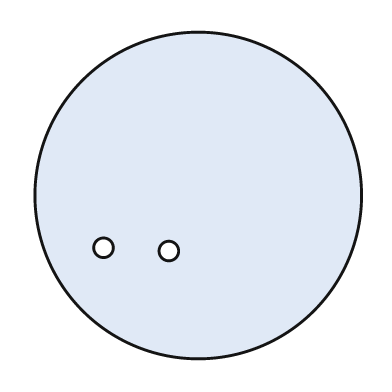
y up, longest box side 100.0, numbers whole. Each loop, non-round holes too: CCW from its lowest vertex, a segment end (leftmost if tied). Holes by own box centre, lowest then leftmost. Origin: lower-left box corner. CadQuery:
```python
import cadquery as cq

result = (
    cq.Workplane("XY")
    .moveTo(50.0, 50.0)
    .circle(50.0)
    .moveTo(41.0, 33.0)
    .circle(3.0)
    .moveTo(21.0, 34.0)
    .circle(3.0)
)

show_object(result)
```